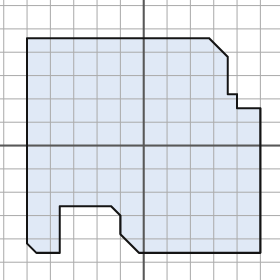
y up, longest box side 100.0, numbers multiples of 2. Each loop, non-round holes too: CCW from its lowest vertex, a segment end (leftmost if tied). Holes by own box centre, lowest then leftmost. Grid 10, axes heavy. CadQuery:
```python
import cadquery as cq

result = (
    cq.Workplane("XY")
    .moveTo(-46.0, -46.0)
    .lineTo(-36.0, -46.0)
    .lineTo(-36.0, -26.0)
    .lineTo(-14.0, -26.0)
    .lineTo(-10.0, -30.0)
    .lineTo(-10.0, -38.0)
    .lineTo(-2.0, -46.0)
    .lineTo(50.0, -46.0)
    .lineTo(50.0, 16.0)
    .lineTo(40.0, 16.0)
    .lineTo(40.0, 22.0)
    .lineTo(36.0, 22.0)
    .lineTo(36.0, 38.0)
    .lineTo(28.0, 46.0)
    .lineTo(-50.0, 46.0)
    .lineTo(-50.0, -42.0)
    .close()
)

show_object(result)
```